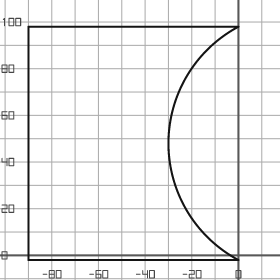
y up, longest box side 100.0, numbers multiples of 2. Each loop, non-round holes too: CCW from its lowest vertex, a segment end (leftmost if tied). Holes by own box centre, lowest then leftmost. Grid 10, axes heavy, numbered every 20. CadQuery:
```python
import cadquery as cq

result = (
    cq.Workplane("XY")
    .moveTo(-90.0, -2.0)
    .lineTo(0.0, -2.0)
    .threePointArc((-30.0, 48.0), (0.0, 98.0))
    .lineTo(-90.0, 98.0)
    .close()
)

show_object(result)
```